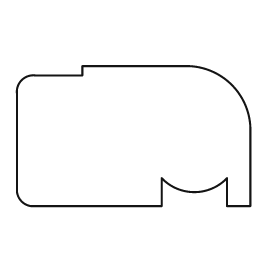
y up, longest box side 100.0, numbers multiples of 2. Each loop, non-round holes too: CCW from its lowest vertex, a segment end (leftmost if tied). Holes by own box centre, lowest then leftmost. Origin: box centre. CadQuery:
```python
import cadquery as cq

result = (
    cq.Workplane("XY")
    .moveTo(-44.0, -30.0)
    .lineTo(12.0, -30.0)
    .lineTo(12.0, -18.0)
    .threePointArc((26.0, -24.0), (40.0, -18.0))
    .lineTo(40.0, -30.0)
    .lineTo(50.0, -30.0)
    .lineTo(50.0, 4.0)
    .threePointArc((42.0, 22.0), (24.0, 30.0))
    .lineTo(-22.0, 30.0)
    .lineTo(-22.0, 26.0)
    .lineTo(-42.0, 26.0)
    .threePointArc((-48.0, 24.0), (-50.0, 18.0))
    .lineTo(-50.0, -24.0)
    .threePointArc((-48.0, -28.0), (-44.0, -30.0))
    .close()
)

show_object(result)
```